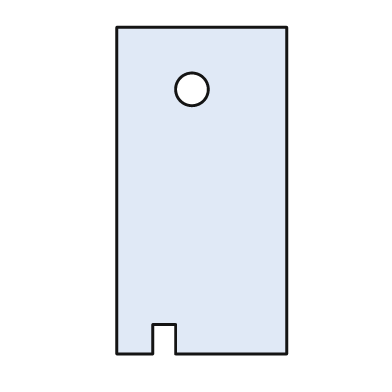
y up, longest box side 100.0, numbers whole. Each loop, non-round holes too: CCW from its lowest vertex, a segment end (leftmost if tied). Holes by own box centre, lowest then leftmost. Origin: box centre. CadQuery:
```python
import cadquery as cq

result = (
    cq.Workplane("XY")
    .moveTo(-26.0, -50.0)
    .lineTo(-15.0, -50.0)
    .lineTo(-15.0, -41.0)
    .lineTo(-8.0, -41.0)
    .lineTo(-8.0, -50.0)
    .lineTo(26.0, -50.0)
    .lineTo(26.0, 50.0)
    .lineTo(-26.0, 50.0)
    .close()
    .moveTo(-3.0, 31.0)
    .circle(5.0)
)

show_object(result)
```